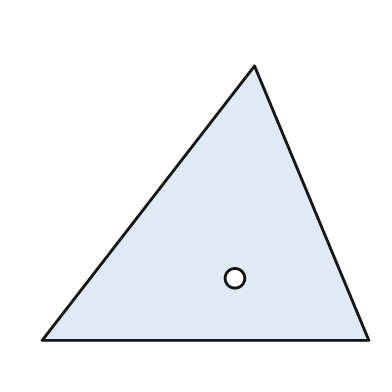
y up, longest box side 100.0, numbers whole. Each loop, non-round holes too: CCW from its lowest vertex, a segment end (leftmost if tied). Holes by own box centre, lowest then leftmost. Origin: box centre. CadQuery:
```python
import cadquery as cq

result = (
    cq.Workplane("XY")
    .moveTo(-50.0, -42.0)
    .lineTo(50.0, -42.0)
    .lineTo(15.0, 42.0)
    .close()
    .moveTo(9.0, -23.0)
    .circle(3.0)
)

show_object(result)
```